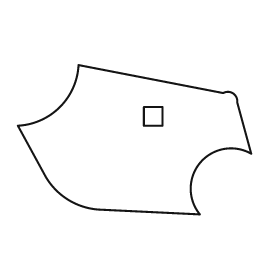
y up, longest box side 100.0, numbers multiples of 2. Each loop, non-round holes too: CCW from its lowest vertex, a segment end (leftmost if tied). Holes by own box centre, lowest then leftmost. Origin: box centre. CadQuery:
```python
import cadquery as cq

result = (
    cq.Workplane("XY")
    .moveTo(28.0, -32.0)
    .threePointArc((28.0, -10.0), (50.0, -6.0))
    .lineTo(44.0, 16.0)
    .threePointArc((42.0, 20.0), (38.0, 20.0))
    .lineTo(-24.0, 32.0)
    .threePointArc((-32.0, 14.0), (-50.0, 6.0))
    .lineTo(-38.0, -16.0)
    .threePointArc((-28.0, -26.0), (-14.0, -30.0))
    .close()
    .moveTo(4.0, 6.0)
    .lineTo(12.0, 6.0)
    .lineTo(12.0, 14.0)
    .lineTo(4.0, 14.0)
    .close()
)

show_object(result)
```